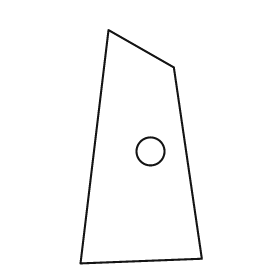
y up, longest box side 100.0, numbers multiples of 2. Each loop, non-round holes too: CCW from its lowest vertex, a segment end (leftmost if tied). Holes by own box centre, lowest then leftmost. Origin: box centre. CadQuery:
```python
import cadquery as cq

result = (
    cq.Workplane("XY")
    .moveTo(-26.0, -50.0)
    .lineTo(26.0, -48.0)
    .lineTo(14.0, 34.0)
    .lineTo(-14.0, 50.0)
    .close()
    .moveTo(4.0, -2.0)
    .circle(6.0)
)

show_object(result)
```